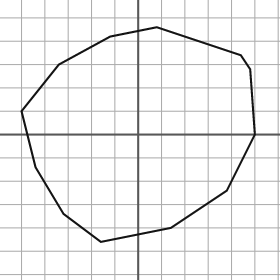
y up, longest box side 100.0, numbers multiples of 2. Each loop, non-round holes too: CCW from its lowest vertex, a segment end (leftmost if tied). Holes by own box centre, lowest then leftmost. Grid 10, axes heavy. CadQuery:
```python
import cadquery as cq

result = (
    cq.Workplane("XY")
    .moveTo(-16.0, -46.0)
    .lineTo(14.0, -40.0)
    .lineTo(38.0, -24.0)
    .lineTo(50.0, 0.0)
    .lineTo(48.0, 28.0)
    .lineTo(44.0, 34.0)
    .lineTo(8.0, 46.0)
    .lineTo(-12.0, 42.0)
    .lineTo(-34.0, 30.0)
    .lineTo(-50.0, 10.0)
    .lineTo(-44.0, -14.0)
    .lineTo(-32.0, -34.0)
    .close()
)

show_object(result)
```